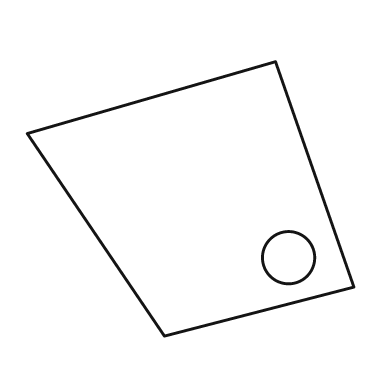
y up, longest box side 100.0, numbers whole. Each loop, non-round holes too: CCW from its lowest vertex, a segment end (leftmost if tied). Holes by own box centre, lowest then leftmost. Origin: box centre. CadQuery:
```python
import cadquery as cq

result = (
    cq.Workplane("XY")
    .moveTo(-8.0, -42.0)
    .lineTo(50.0, -27.0)
    .lineTo(26.0, 42.0)
    .lineTo(-50.0, 20.0)
    .close()
    .moveTo(30.0, -18.0)
    .circle(8.0)
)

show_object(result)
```